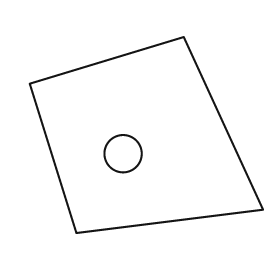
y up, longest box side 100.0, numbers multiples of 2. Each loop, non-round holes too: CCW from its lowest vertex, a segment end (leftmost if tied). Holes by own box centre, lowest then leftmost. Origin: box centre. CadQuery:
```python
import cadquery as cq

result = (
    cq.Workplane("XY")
    .moveTo(-30.0, -42.0)
    .lineTo(50.0, -32.0)
    .lineTo(16.0, 42.0)
    .lineTo(-50.0, 22.0)
    .close()
    .moveTo(-10.0, -8.0)
    .circle(8.0)
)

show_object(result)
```